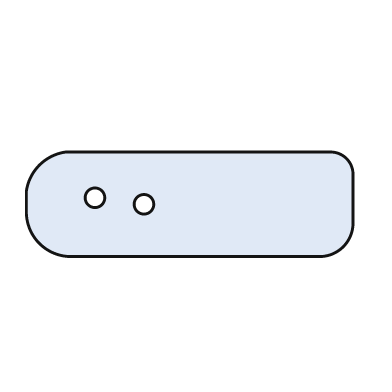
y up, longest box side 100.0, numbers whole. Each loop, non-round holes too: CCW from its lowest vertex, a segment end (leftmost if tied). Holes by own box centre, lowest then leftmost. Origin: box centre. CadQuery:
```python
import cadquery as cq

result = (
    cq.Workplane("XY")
    .moveTo(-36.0, -16.0)
    .lineTo(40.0, -16.0)
    .threePointArc((47.0, -13.0), (50.0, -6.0))
    .lineTo(50.0, 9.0)
    .threePointArc((48.0, 14.0), (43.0, 16.0))
    .lineTo(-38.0, 16.0)
    .threePointArc((-46.0, 12.0), (-50.0, 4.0))
    .lineTo(-50.0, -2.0)
    .threePointArc((-46.0, -12.0), (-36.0, -16.0))
    .close()
    .moveTo(-14.0, 0.0)
    .circle(3.0)
    .moveTo(-29.0, 2.0)
    .circle(3.0)
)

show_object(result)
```